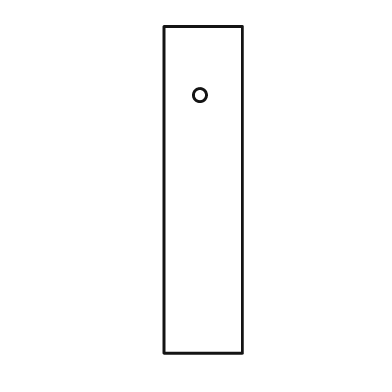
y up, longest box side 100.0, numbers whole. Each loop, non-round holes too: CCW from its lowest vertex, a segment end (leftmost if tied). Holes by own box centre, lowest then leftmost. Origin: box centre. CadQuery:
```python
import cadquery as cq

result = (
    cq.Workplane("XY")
    .moveTo(-12.0, -50.0)
    .lineTo(12.0, -50.0)
    .lineTo(12.0, 50.0)
    .lineTo(-12.0, 50.0)
    .close()
    .moveTo(-1.0, 29.0)
    .circle(2.0)
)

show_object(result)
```